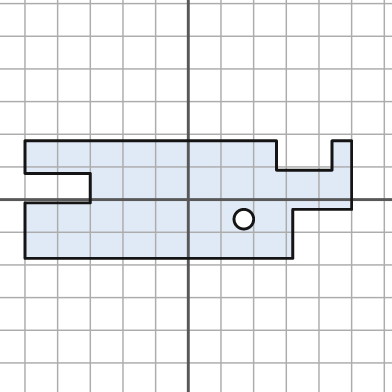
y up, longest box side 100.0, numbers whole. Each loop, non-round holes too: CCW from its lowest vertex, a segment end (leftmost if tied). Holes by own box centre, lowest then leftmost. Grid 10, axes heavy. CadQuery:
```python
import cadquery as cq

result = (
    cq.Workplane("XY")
    .moveTo(-50.0, -18.0)
    .lineTo(32.0, -18.0)
    .lineTo(32.0, -3.0)
    .lineTo(50.0, -3.0)
    .lineTo(50.0, 18.0)
    .lineTo(44.0, 18.0)
    .lineTo(44.0, 9.0)
    .lineTo(27.0, 9.0)
    .lineTo(27.0, 18.0)
    .lineTo(-50.0, 18.0)
    .lineTo(-50.0, 8.0)
    .lineTo(-30.0, 8.0)
    .lineTo(-30.0, -1.0)
    .lineTo(-50.0, -1.0)
    .close()
    .moveTo(17.0, -6.0)
    .circle(3.0)
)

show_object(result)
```